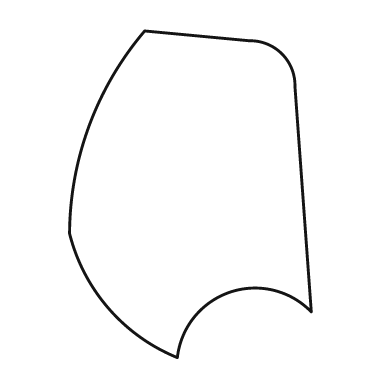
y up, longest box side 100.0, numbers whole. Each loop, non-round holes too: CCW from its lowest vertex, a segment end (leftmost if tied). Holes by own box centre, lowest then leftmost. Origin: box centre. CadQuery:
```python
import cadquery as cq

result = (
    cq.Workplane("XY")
    .moveTo(-4.0, -50.0)
    .threePointArc((12.0, -30.0), (37.0, -36.0))
    .lineTo(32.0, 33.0)
    .threePointArc((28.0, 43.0), (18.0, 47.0))
    .lineTo(-14.0, 50.0)
    .threePointArc((-31.0, 21.0), (-37.0, -12.0))
    .threePointArc((-25.0, -35.0), (-4.0, -50.0))
    .close()
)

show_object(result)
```